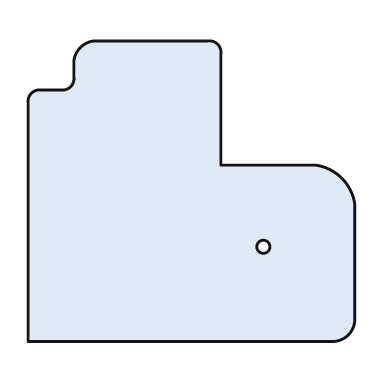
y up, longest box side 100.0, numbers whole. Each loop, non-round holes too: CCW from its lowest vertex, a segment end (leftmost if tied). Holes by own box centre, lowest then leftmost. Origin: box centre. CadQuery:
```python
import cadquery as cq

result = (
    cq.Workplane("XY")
    .moveTo(-50.0, -46.0)
    .lineTo(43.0, -46.0)
    .threePointArc((48.0, -44.0), (50.0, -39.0))
    .lineTo(50.0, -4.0)
    .threePointArc((46.0, 4.0), (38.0, 8.0))
    .lineTo(9.0, 8.0)
    .lineTo(9.0, 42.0)
    .threePointArc((8.0, 45.0), (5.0, 46.0))
    .lineTo(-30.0, 46.0)
    .threePointArc((-34.0, 44.0), (-36.0, 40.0))
    .lineTo(-36.0, 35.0)
    .threePointArc((-37.0, 32.0), (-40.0, 31.0))
    .lineTo(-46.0, 31.0)
    .threePointArc((-49.0, 30.0), (-50.0, 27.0))
    .close()
    .moveTo(22.0, -17.0)
    .circle(2.0)
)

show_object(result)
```